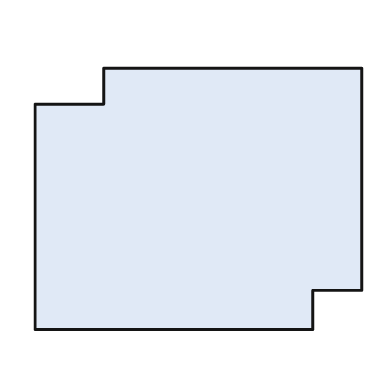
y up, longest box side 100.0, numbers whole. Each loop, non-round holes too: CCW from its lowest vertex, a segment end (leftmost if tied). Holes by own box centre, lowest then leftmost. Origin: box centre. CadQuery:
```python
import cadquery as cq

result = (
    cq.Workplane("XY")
    .moveTo(-50.0, -40.0)
    .lineTo(35.0, -40.0)
    .lineTo(35.0, -28.0)
    .lineTo(50.0, -28.0)
    .lineTo(50.0, 40.0)
    .lineTo(-29.0, 40.0)
    .lineTo(-29.0, 29.0)
    .lineTo(-50.0, 29.0)
    .close()
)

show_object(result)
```